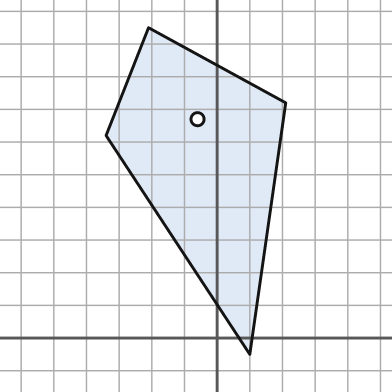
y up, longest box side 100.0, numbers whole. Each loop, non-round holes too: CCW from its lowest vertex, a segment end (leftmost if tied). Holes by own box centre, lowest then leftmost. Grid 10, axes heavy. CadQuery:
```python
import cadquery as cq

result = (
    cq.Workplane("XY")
    .moveTo(10.0, -5.0)
    .lineTo(21.0, 72.0)
    .lineTo(-21.0, 95.0)
    .lineTo(-34.0, 62.0)
    .close()
    .moveTo(-6.0, 67.0)
    .circle(2.0)
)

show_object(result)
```